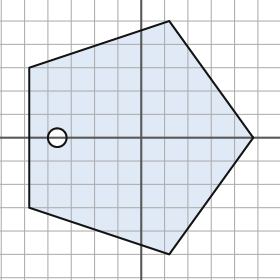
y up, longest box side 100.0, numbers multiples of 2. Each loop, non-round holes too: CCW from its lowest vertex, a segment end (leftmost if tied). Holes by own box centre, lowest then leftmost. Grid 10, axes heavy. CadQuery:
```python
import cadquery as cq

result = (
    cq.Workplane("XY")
    .moveTo(12.0, -50.0)
    .lineTo(48.0, 0.0)
    .lineTo(12.0, 50.0)
    .lineTo(-48.0, 30.0)
    .lineTo(-48.0, -30.0)
    .close()
    .moveTo(-36.0, 0.0)
    .circle(4.0)
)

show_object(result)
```